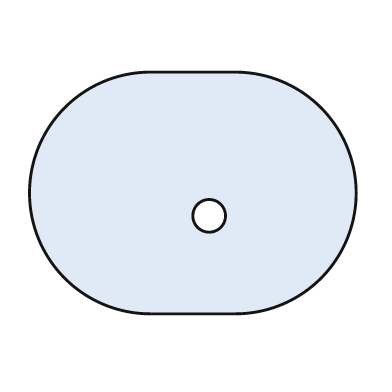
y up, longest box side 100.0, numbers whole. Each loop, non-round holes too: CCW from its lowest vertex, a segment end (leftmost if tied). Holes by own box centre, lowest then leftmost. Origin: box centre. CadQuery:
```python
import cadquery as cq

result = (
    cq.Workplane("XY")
    .moveTo(-13.0, -37.0)
    .lineTo(13.0, -37.0)
    .threePointArc((50.0, 0.0), (13.0, 37.0))
    .lineTo(-13.0, 37.0)
    .threePointArc((-50.0, 0.0), (-13.0, -37.0))
    .close()
    .moveTo(5.0, -7.0)
    .circle(5.0)
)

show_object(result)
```